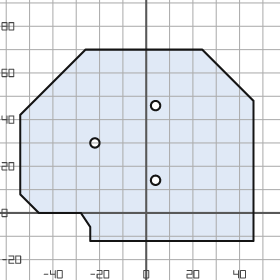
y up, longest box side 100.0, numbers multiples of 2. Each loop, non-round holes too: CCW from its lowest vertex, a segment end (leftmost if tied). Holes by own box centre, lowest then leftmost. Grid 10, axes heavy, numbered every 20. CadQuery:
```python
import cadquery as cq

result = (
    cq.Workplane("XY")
    .moveTo(-24.0, -12.0)
    .lineTo(46.0, -12.0)
    .lineTo(46.0, 48.0)
    .lineTo(24.0, 70.0)
    .lineTo(-26.0, 70.0)
    .lineTo(-54.0, 42.0)
    .lineTo(-54.0, 8.0)
    .lineTo(-46.0, 0.0)
    .lineTo(-28.0, 0.0)
    .lineTo(-24.0, -6.0)
    .close()
    .moveTo(4.0, 14.0)
    .circle(2.0)
    .moveTo(-22.0, 30.0)
    .circle(2.0)
    .moveTo(4.0, 46.0)
    .circle(2.0)
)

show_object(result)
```